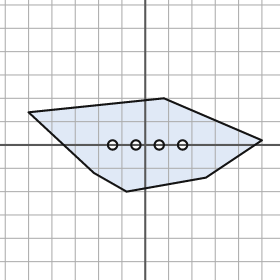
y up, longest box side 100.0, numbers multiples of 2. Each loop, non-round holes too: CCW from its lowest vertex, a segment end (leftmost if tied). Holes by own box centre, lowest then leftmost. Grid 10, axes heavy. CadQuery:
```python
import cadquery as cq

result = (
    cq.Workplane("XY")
    .moveTo(-8.0, -20.0)
    .lineTo(26.0, -14.0)
    .lineTo(50.0, 2.0)
    .lineTo(8.0, 20.0)
    .lineTo(-50.0, 14.0)
    .lineTo(-22.0, -12.0)
    .close()
    .moveTo(-14.0, 0.0)
    .circle(2.0)
    .moveTo(-4.0, 0.0)
    .circle(2.0)
    .moveTo(6.0, 0.0)
    .circle(2.0)
    .moveTo(16.0, 0.0)
    .circle(2.0)
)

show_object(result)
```